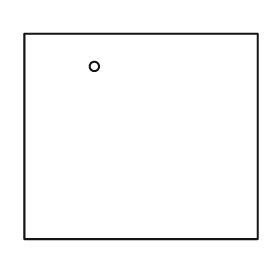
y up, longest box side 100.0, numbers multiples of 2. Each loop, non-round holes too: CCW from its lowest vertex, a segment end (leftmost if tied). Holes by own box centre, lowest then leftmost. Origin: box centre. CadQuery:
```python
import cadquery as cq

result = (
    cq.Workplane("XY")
    .moveTo(-50.0, -44.0)
    .lineTo(50.0, -44.0)
    .lineTo(50.0, 44.0)
    .lineTo(-50.0, 44.0)
    .close()
    .moveTo(-20.0, 30.0)
    .circle(2.0)
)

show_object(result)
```